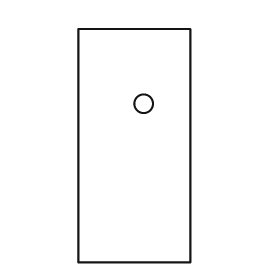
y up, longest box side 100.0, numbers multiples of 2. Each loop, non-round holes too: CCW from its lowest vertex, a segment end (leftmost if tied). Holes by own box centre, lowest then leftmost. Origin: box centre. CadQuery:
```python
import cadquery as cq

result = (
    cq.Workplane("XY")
    .moveTo(-24.0, -50.0)
    .lineTo(24.0, -50.0)
    .lineTo(24.0, 50.0)
    .lineTo(-24.0, 50.0)
    .close()
    .moveTo(4.0, 18.0)
    .circle(4.0)
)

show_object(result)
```